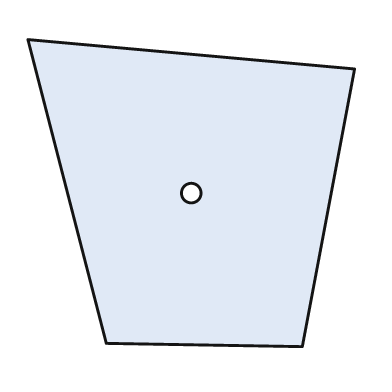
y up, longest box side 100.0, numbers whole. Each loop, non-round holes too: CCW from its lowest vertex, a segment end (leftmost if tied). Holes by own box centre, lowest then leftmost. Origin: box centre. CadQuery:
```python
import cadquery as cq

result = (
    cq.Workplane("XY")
    .moveTo(34.0, -47.0)
    .lineTo(50.0, 38.0)
    .lineTo(-50.0, 47.0)
    .lineTo(-26.0, -46.0)
    .close()
    .moveTo(0.0, 0.0)
    .circle(3.0)
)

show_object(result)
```